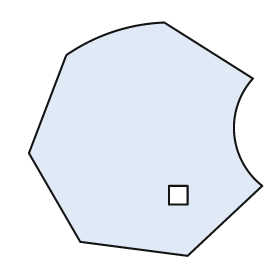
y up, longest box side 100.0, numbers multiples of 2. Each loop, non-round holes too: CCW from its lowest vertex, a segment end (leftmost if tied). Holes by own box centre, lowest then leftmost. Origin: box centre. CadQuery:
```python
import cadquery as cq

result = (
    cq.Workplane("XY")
    .moveTo(18.0, -50.0)
    .lineTo(50.0, -20.0)
    .threePointArc((38.0, 2.0), (46.0, 26.0))
    .lineTo(8.0, 50.0)
    .threePointArc((-14.0, 46.0), (-34.0, 36.0))
    .lineTo(-50.0, -6.0)
    .lineTo(-28.0, -44.0)
    .close()
    .moveTo(10.0, -28.0)
    .lineTo(18.0, -28.0)
    .lineTo(18.0, -20.0)
    .lineTo(10.0, -20.0)
    .close()
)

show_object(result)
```